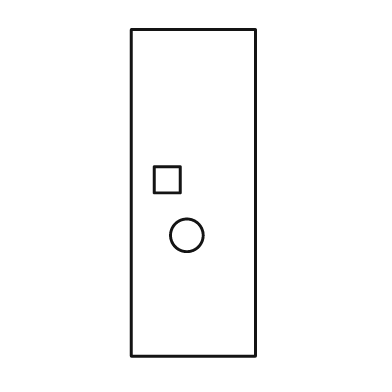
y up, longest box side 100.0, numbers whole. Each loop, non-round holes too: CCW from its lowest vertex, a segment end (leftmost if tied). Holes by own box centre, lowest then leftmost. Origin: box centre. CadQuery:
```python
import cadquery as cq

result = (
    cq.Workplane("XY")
    .moveTo(-19.0, -50.0)
    .lineTo(19.0, -50.0)
    .lineTo(19.0, 50.0)
    .lineTo(-19.0, 50.0)
    .close()
    .moveTo(-2.0, -13.0)
    .circle(5.0)
    .moveTo(-12.0, 0.0)
    .lineTo(-4.0, 0.0)
    .lineTo(-4.0, 8.0)
    .lineTo(-12.0, 8.0)
    .close()
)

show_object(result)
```